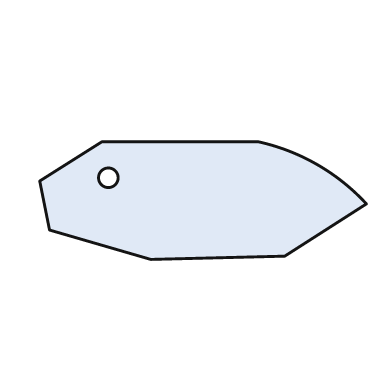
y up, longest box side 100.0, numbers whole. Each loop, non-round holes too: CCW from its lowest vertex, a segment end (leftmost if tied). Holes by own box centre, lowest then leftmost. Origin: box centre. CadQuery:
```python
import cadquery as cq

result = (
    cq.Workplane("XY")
    .moveTo(-16.0, -18.0)
    .lineTo(25.0, -17.0)
    .lineTo(50.0, -1.0)
    .threePointArc((35.0, 11.0), (17.0, 18.0))
    .lineTo(-31.0, 18.0)
    .lineTo(-50.0, 6.0)
    .lineTo(-47.0, -9.0)
    .close()
    .moveTo(-29.0, 7.0)
    .circle(3.0)
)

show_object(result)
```